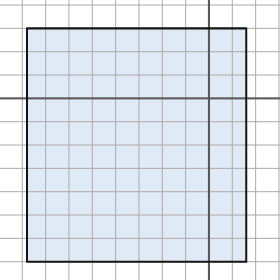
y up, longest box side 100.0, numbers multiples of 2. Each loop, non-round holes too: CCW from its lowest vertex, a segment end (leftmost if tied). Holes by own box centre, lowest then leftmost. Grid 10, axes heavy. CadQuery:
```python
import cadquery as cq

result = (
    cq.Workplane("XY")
    .moveTo(-78.0, -70.0)
    .lineTo(16.0, -70.0)
    .lineTo(16.0, 30.0)
    .lineTo(-78.0, 30.0)
    .close()
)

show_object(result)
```